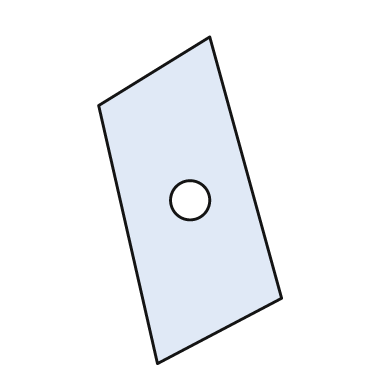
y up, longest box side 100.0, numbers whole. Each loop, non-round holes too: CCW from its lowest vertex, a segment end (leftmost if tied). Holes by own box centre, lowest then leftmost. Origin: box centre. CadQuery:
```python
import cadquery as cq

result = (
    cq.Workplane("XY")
    .moveTo(-10.0, -50.0)
    .lineTo(28.0, -30.0)
    .lineTo(6.0, 50.0)
    .lineTo(-28.0, 29.0)
    .close()
    .moveTo(0.0, 0.0)
    .circle(6.0)
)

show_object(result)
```